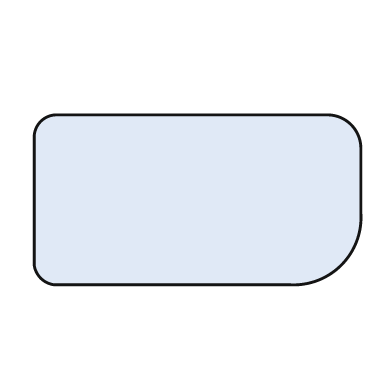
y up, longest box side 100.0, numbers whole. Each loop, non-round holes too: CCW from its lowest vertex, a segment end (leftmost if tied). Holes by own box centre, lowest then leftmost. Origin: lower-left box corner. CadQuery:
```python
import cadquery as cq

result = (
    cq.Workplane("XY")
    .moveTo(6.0, 0.0)
    .lineTo(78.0, 0.0)
    .threePointArc((94.0, 6.0), (100.0, 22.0))
    .lineTo(100.0, 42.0)
    .threePointArc((97.0, 49.0), (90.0, 52.0))
    .lineTo(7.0, 52.0)
    .threePointArc((2.0, 50.0), (0.0, 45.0))
    .lineTo(0.0, 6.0)
    .threePointArc((2.0, 2.0), (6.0, 0.0))
    .close()
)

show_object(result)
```